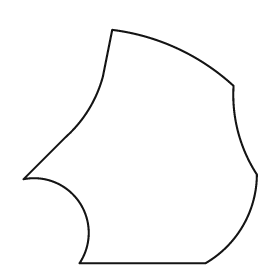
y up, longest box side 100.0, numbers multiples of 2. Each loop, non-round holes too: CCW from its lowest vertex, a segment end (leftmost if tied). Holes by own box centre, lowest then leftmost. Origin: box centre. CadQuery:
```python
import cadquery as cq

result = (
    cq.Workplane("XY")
    .moveTo(-26.0, -50.0)
    .lineTo(28.0, -50.0)
    .threePointArc((44.0, -34.0), (50.0, -12.0))
    .threePointArc((42.0, 6.0), (40.0, 26.0))
    .threePointArc((16.0, 42.0), (-12.0, 50.0))
    .lineTo(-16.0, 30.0)
    .threePointArc((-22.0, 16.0), (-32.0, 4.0))
    .lineTo(-50.0, -14.0)
    .threePointArc((-26.0, -24.0), (-26.0, -50.0))
    .close()
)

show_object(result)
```